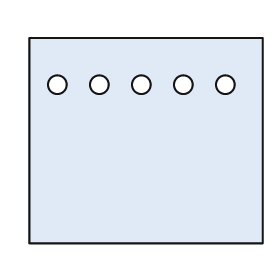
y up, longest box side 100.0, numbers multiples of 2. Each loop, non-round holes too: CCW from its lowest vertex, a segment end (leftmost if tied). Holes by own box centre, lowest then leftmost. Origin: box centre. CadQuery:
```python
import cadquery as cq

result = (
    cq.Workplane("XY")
    .moveTo(-50.0, -44.0)
    .lineTo(50.0, -44.0)
    .lineTo(50.0, 44.0)
    .lineTo(-50.0, 44.0)
    .close()
    .moveTo(-38.0, 24.0)
    .circle(4.0)
    .moveTo(-20.0, 24.0)
    .circle(4.0)
    .moveTo(-2.0, 24.0)
    .circle(4.0)
    .moveTo(16.0, 24.0)
    .circle(4.0)
    .moveTo(34.0, 24.0)
    .circle(4.0)
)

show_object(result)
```